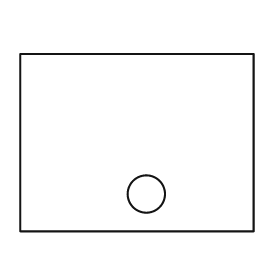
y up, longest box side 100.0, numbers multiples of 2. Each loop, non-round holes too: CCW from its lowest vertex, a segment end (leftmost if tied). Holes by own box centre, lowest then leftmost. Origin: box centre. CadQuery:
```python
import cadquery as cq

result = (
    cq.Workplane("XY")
    .moveTo(-50.0, -38.0)
    .lineTo(50.0, -38.0)
    .lineTo(50.0, 38.0)
    .lineTo(-50.0, 38.0)
    .close()
    .moveTo(4.0, -22.0)
    .circle(8.0)
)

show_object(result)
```